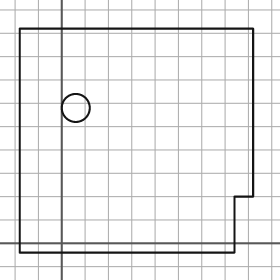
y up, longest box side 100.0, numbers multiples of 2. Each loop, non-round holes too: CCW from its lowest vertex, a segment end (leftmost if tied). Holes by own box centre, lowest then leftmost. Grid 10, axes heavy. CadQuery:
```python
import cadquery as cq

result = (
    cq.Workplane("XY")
    .moveTo(-18.0, -4.0)
    .lineTo(74.0, -4.0)
    .lineTo(74.0, 20.0)
    .lineTo(82.0, 20.0)
    .lineTo(82.0, 92.0)
    .lineTo(-18.0, 92.0)
    .close()
    .moveTo(6.0, 58.0)
    .circle(6.0)
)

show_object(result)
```